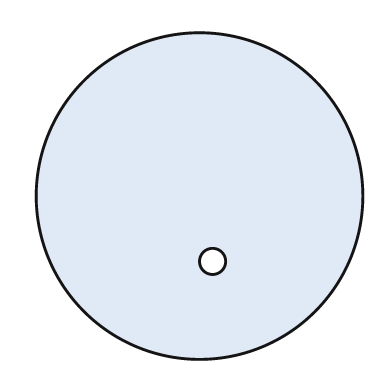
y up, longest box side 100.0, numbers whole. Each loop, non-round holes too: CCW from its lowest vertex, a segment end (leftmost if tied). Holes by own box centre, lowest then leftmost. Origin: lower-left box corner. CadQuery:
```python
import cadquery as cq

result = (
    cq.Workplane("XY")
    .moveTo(50.0, 50.0)
    .circle(50.0)
    .moveTo(54.0, 30.0)
    .circle(4.0)
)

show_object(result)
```